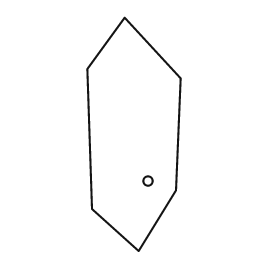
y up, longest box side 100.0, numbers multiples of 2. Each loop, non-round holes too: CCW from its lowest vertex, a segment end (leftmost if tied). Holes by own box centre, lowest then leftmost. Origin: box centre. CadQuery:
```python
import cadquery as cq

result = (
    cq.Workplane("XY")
    .moveTo(2.0, -50.0)
    .lineTo(18.0, -24.0)
    .lineTo(20.0, 24.0)
    .lineTo(-4.0, 50.0)
    .lineTo(-20.0, 28.0)
    .lineTo(-18.0, -32.0)
    .close()
    .moveTo(6.0, -20.0)
    .circle(2.0)
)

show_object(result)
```